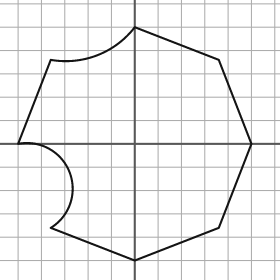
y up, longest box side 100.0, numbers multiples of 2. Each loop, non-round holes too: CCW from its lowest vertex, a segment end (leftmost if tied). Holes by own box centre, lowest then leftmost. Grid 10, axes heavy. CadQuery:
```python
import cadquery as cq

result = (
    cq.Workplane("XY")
    .moveTo(0.0, -50.0)
    .lineTo(36.0, -36.0)
    .lineTo(50.0, 0.0)
    .lineTo(36.0, 36.0)
    .lineTo(0.0, 50.0)
    .threePointArc((-16.0, 38.0), (-36.0, 36.0))
    .lineTo(-50.0, 0.0)
    .threePointArc((-28.0, -12.0), (-36.0, -36.0))
    .close()
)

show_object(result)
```